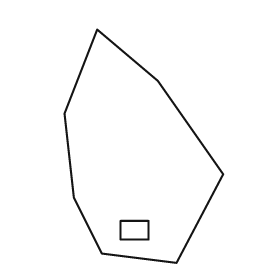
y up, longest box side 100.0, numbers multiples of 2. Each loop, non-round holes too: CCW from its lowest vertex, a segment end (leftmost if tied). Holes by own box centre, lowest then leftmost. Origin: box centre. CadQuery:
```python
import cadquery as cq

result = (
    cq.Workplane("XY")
    .moveTo(14.0, -50.0)
    .lineTo(34.0, -12.0)
    .lineTo(6.0, 28.0)
    .lineTo(-20.0, 50.0)
    .lineTo(-34.0, 14.0)
    .lineTo(-30.0, -22.0)
    .lineTo(-18.0, -46.0)
    .close()
    .moveTo(-10.0, -40.0)
    .lineTo(2.0, -40.0)
    .lineTo(2.0, -32.0)
    .lineTo(-10.0, -32.0)
    .close()
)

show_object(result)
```